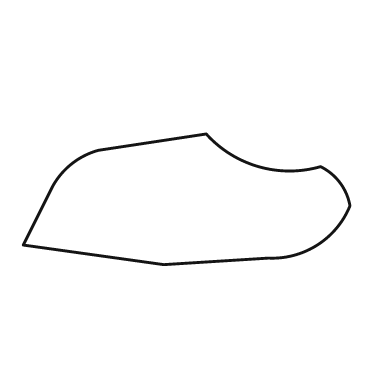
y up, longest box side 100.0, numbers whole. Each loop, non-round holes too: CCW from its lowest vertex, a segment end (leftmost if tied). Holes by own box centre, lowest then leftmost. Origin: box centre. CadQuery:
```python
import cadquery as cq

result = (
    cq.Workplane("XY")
    .moveTo(-7.0, -20.0)
    .lineTo(25.0, -18.0)
    .threePointArc((40.0, -14.0), (50.0, -2.0))
    .threePointArc((47.0, 5.0), (41.0, 10.0))
    .threePointArc((22.0, 10.0), (6.0, 20.0))
    .lineTo(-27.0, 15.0)
    .threePointArc((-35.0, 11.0), (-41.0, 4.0))
    .lineTo(-50.0, -14.0)
    .close()
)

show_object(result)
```